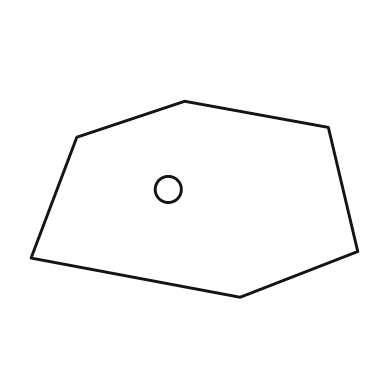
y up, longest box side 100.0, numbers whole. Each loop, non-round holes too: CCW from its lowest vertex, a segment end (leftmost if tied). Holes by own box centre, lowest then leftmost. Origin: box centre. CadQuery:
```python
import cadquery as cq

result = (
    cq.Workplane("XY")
    .moveTo(14.0, -30.0)
    .lineTo(50.0, -16.0)
    .lineTo(41.0, 22.0)
    .lineTo(-3.0, 30.0)
    .lineTo(-36.0, 19.0)
    .lineTo(-50.0, -18.0)
    .close()
    .moveTo(-8.0, 3.0)
    .circle(4.0)
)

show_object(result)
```